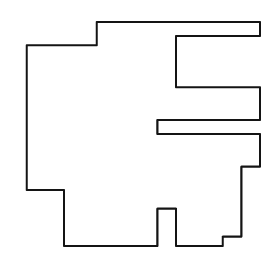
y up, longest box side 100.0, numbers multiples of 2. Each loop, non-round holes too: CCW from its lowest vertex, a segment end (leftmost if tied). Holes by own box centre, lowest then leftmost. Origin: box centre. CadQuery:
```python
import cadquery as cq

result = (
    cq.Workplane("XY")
    .moveTo(-34.0, -48.0)
    .lineTo(6.0, -48.0)
    .lineTo(6.0, -32.0)
    .lineTo(14.0, -32.0)
    .lineTo(14.0, -48.0)
    .lineTo(34.0, -48.0)
    .lineTo(34.0, -44.0)
    .lineTo(42.0, -44.0)
    .lineTo(42.0, -14.0)
    .lineTo(50.0, -14.0)
    .lineTo(50.0, 0.0)
    .lineTo(6.0, 0.0)
    .lineTo(6.0, 6.0)
    .lineTo(50.0, 6.0)
    .lineTo(50.0, 20.0)
    .lineTo(14.0, 20.0)
    .lineTo(14.0, 42.0)
    .lineTo(50.0, 42.0)
    .lineTo(50.0, 48.0)
    .lineTo(-20.0, 48.0)
    .lineTo(-20.0, 38.0)
    .lineTo(-50.0, 38.0)
    .lineTo(-50.0, -24.0)
    .lineTo(-34.0, -24.0)
    .close()
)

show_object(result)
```